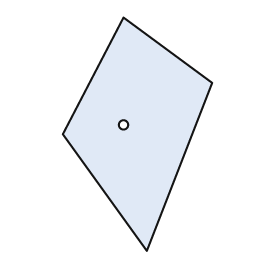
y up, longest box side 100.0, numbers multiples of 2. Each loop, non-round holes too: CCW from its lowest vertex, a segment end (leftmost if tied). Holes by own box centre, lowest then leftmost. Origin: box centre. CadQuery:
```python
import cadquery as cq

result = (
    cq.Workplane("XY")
    .moveTo(4.0, -50.0)
    .lineTo(32.0, 22.0)
    .lineTo(-6.0, 50.0)
    .lineTo(-32.0, 0.0)
    .close()
    .moveTo(-6.0, 4.0)
    .circle(2.0)
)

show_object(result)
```